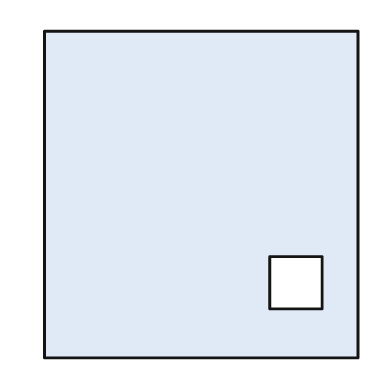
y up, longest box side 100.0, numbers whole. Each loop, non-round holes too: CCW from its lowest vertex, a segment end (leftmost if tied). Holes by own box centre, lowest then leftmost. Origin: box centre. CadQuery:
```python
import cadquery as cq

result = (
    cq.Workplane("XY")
    .moveTo(-48.0, -50.0)
    .lineTo(48.0, -50.0)
    .lineTo(48.0, 50.0)
    .lineTo(-48.0, 50.0)
    .close()
    .moveTo(21.0, -35.0)
    .lineTo(37.0, -35.0)
    .lineTo(37.0, -19.0)
    .lineTo(21.0, -19.0)
    .close()
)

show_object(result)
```